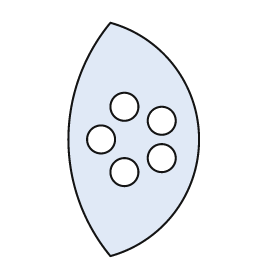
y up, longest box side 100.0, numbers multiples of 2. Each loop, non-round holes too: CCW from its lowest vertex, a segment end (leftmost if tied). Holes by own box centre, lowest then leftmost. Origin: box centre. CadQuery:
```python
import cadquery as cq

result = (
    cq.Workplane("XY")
    .moveTo(-10.0, -50.0)
    .threePointArc((28.0, 0.0), (-10.0, 50.0))
    .threePointArc((-28.0, 0.0), (-10.0, -50.0))
    .close()
    .moveTo(-4.0, -14.0)
    .circle(6.0)
    .moveTo(12.0, -8.0)
    .circle(6.0)
    .moveTo(-14.0, 0.0)
    .circle(6.0)
    .moveTo(12.0, 8.0)
    .circle(6.0)
    .moveTo(-4.0, 14.0)
    .circle(6.0)
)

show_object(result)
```